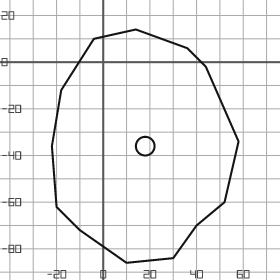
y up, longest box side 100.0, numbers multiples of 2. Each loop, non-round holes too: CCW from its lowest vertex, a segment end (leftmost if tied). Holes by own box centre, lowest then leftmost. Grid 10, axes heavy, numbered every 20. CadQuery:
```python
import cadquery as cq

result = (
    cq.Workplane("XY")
    .moveTo(10.0, -86.0)
    .lineTo(30.0, -84.0)
    .lineTo(40.0, -70.0)
    .lineTo(52.0, -60.0)
    .lineTo(58.0, -34.0)
    .lineTo(44.0, -2.0)
    .lineTo(36.0, 6.0)
    .lineTo(14.0, 14.0)
    .lineTo(-4.0, 10.0)
    .lineTo(-18.0, -12.0)
    .lineTo(-22.0, -36.0)
    .lineTo(-20.0, -62.0)
    .lineTo(-10.0, -72.0)
    .close()
    .moveTo(18.0, -36.0)
    .circle(4.0)
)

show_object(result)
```